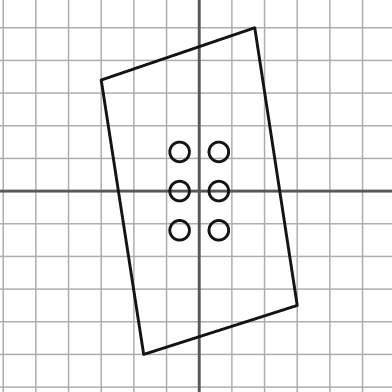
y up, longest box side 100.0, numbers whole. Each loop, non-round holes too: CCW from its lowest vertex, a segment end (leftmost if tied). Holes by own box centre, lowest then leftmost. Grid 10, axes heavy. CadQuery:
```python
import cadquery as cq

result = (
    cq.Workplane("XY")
    .moveTo(-17.0, -50.0)
    .lineTo(30.0, -35.0)
    .lineTo(17.0, 50.0)
    .lineTo(-30.0, 34.0)
    .close()
    .moveTo(-6.0, -12.0)
    .circle(3.0)
    .moveTo(6.0, -12.0)
    .circle(3.0)
    .moveTo(-6.0, 0.0)
    .circle(3.0)
    .moveTo(6.0, 0.0)
    .circle(3.0)
    .moveTo(-6.0, 12.0)
    .circle(3.0)
    .moveTo(6.0, 12.0)
    .circle(3.0)
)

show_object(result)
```